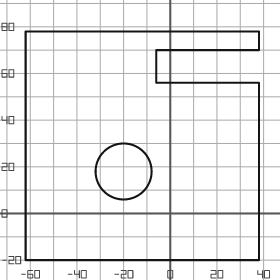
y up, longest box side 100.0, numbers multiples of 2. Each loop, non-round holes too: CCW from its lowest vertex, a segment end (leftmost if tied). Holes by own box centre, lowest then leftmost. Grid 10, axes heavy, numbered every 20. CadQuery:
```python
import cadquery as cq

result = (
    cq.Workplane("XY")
    .moveTo(-62.0, -20.0)
    .lineTo(38.0, -20.0)
    .lineTo(38.0, 56.0)
    .lineTo(-6.0, 56.0)
    .lineTo(-6.0, 70.0)
    .lineTo(38.0, 70.0)
    .lineTo(38.0, 78.0)
    .lineTo(-62.0, 78.0)
    .close()
    .moveTo(-20.0, 18.0)
    .circle(12.0)
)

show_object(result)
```